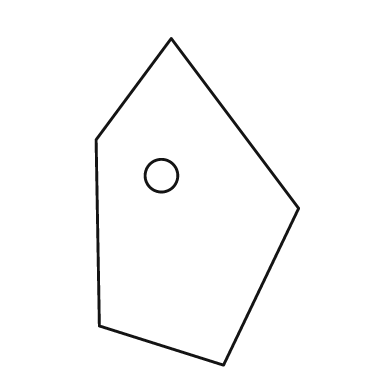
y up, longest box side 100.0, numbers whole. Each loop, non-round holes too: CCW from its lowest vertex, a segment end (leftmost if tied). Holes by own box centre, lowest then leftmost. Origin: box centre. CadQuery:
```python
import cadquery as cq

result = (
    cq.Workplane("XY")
    .moveTo(8.0, -50.0)
    .lineTo(31.0, -2.0)
    .lineTo(-8.0, 50.0)
    .lineTo(-31.0, 19.0)
    .lineTo(-30.0, -38.0)
    .close()
    .moveTo(-11.0, 8.0)
    .circle(5.0)
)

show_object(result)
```